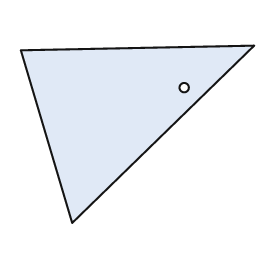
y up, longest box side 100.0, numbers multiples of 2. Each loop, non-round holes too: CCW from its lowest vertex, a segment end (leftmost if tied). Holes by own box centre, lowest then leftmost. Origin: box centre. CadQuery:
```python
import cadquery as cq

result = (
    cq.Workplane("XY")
    .moveTo(-28.0, -38.0)
    .lineTo(50.0, 38.0)
    .lineTo(-50.0, 36.0)
    .close()
    .moveTo(20.0, 20.0)
    .circle(2.0)
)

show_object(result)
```